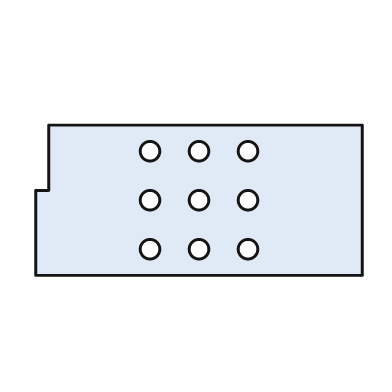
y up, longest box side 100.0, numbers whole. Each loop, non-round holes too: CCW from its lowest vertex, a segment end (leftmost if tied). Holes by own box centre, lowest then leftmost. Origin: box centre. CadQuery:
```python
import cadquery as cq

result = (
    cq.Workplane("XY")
    .moveTo(-50.0, -23.0)
    .lineTo(50.0, -23.0)
    .lineTo(50.0, 23.0)
    .lineTo(-46.0, 23.0)
    .lineTo(-46.0, 3.0)
    .lineTo(-50.0, 3.0)
    .close()
    .moveTo(-15.0, -15.0)
    .circle(3.0)
    .moveTo(0.0, -15.0)
    .circle(3.0)
    .moveTo(15.0, -15.0)
    .circle(3.0)
    .moveTo(-15.0, 0.0)
    .circle(3.0)
    .moveTo(0.0, 0.0)
    .circle(3.0)
    .moveTo(15.0, 0.0)
    .circle(3.0)
    .moveTo(-15.0, 15.0)
    .circle(3.0)
    .moveTo(0.0, 15.0)
    .circle(3.0)
    .moveTo(15.0, 15.0)
    .circle(3.0)
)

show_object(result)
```